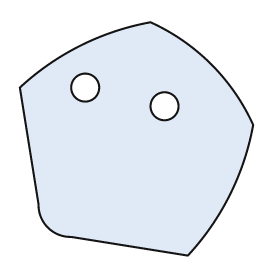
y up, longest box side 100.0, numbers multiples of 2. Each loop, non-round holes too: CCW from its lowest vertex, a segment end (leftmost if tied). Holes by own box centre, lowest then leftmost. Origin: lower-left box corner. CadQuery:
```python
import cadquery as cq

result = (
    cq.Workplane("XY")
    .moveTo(72.0, 0.0)
    .threePointArc((90.0, 26.0), (100.0, 56.0))
    .threePointArc((82.0, 82.0), (56.0, 100.0))
    .threePointArc((26.0, 90.0), (0.0, 72.0))
    .lineTo(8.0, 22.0)
    .threePointArc((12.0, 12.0), (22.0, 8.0))
    .close()
    .moveTo(62.0, 64.0)
    .circle(6.0)
    .moveTo(28.0, 72.0)
    .circle(6.0)
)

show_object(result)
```